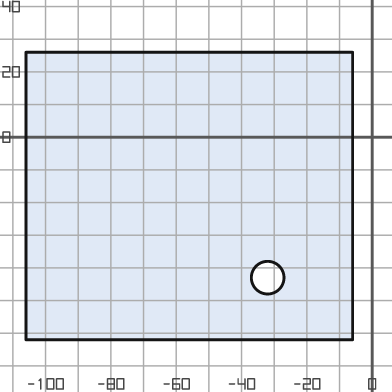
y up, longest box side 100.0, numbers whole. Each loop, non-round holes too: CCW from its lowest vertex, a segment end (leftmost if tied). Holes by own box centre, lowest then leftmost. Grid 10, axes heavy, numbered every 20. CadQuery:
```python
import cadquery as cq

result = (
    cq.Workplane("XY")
    .moveTo(-106.0, -62.0)
    .lineTo(-6.0, -62.0)
    .lineTo(-6.0, 26.0)
    .lineTo(-106.0, 26.0)
    .close()
    .moveTo(-32.0, -43.0)
    .circle(5.0)
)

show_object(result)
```